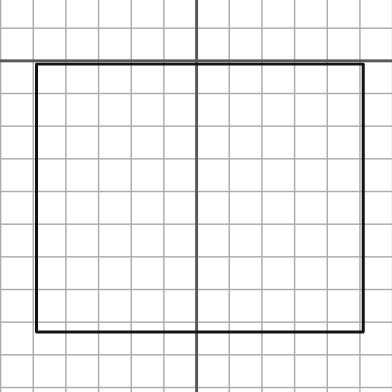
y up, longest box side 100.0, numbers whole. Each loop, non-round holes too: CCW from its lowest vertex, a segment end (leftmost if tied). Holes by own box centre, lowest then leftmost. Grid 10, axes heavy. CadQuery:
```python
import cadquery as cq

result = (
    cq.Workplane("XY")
    .moveTo(-49.0, -83.0)
    .lineTo(51.0, -83.0)
    .lineTo(51.0, -1.0)
    .lineTo(-49.0, -1.0)
    .close()
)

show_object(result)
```